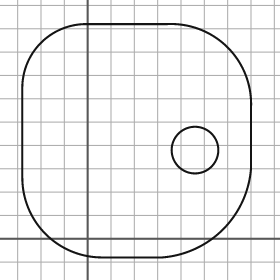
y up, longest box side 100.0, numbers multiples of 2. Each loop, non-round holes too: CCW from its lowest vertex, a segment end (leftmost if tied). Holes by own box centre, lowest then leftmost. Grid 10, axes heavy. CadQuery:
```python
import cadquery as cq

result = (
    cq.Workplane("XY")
    .moveTo(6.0, -8.0)
    .lineTo(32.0, -8.0)
    .threePointArc((58.0, 4.0), (70.0, 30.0))
    .lineTo(70.0, 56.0)
    .threePointArc((60.0, 82.0), (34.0, 92.0))
    .lineTo(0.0, 92.0)
    .threePointArc((-20.0, 84.0), (-28.0, 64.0))
    .lineTo(-28.0, 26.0)
    .threePointArc((-18.0, 2.0), (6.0, -8.0))
    .close()
    .moveTo(46.0, 38.0)
    .circle(10.0)
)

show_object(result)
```